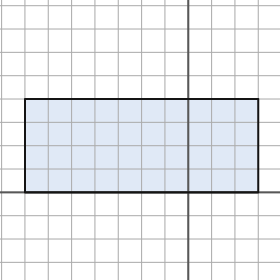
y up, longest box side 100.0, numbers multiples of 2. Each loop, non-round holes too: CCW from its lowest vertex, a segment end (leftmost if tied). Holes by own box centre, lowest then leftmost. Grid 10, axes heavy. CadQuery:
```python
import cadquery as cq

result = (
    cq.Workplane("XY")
    .moveTo(-70.0, 0.0)
    .lineTo(30.0, 0.0)
    .lineTo(30.0, 40.0)
    .lineTo(-70.0, 40.0)
    .close()
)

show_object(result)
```